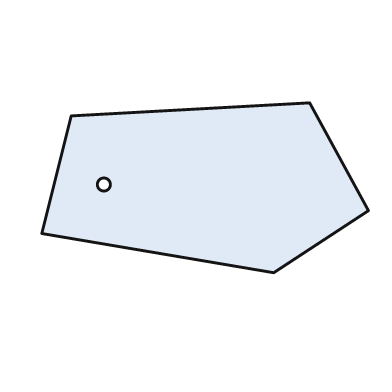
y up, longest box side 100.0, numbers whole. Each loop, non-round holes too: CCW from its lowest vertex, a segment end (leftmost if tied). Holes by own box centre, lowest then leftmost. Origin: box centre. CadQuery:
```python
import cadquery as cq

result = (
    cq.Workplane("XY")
    .moveTo(21.0, -26.0)
    .lineTo(50.0, -7.0)
    .lineTo(32.0, 26.0)
    .lineTo(-41.0, 22.0)
    .lineTo(-50.0, -14.0)
    .close()
    .moveTo(-31.0, 1.0)
    .circle(2.0)
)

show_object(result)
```